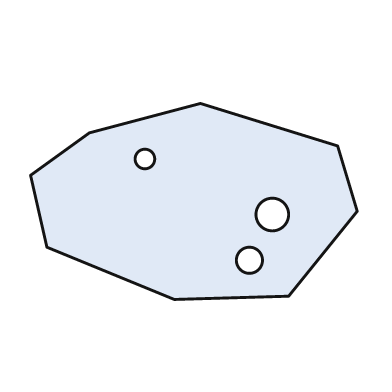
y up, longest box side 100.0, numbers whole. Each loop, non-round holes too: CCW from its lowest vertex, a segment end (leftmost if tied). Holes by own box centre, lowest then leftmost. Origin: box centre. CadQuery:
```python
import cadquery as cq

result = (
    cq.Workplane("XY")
    .moveTo(-6.0, -30.0)
    .lineTo(29.0, -29.0)
    .lineTo(50.0, -3.0)
    .lineTo(44.0, 17.0)
    .lineTo(2.0, 30.0)
    .lineTo(-32.0, 21.0)
    .lineTo(-50.0, 8.0)
    .lineTo(-45.0, -14.0)
    .close()
    .moveTo(17.0, -18.0)
    .circle(4.0)
    .moveTo(24.0, -4.0)
    .circle(5.0)
    .moveTo(-15.0, 13.0)
    .circle(3.0)
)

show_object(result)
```